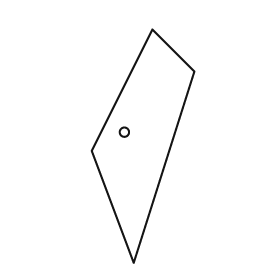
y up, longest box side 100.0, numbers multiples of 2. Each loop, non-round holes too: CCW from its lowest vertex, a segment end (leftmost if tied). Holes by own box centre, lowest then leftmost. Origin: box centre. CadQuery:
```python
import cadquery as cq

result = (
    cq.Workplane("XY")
    .moveTo(-4.0, -50.0)
    .lineTo(22.0, 32.0)
    .lineTo(4.0, 50.0)
    .lineTo(-22.0, -2.0)
    .close()
    .moveTo(-8.0, 6.0)
    .circle(2.0)
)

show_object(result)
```